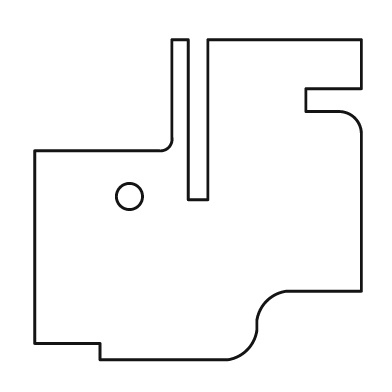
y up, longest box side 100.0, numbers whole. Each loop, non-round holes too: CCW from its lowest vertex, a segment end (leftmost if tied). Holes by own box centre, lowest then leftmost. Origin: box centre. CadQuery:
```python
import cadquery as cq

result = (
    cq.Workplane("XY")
    .moveTo(-30.0, -49.0)
    .lineTo(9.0, -49.0)
    .threePointArc((15.0, -46.0), (18.0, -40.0))
    .lineTo(18.0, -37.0)
    .threePointArc((21.0, -31.0), (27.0, -28.0))
    .lineTo(50.0, -28.0)
    .lineTo(50.0, 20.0)
    .threePointArc((48.0, 25.0), (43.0, 27.0))
    .lineTo(33.0, 27.0)
    .lineTo(33.0, 34.0)
    .lineTo(50.0, 34.0)
    .lineTo(50.0, 49.0)
    .lineTo(3.0, 49.0)
    .lineTo(3.0, 0.0)
    .lineTo(-3.0, 0.0)
    .lineTo(-3.0, 49.0)
    .lineTo(-8.0, 49.0)
    .lineTo(-8.0, 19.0)
    .threePointArc((-9.0, 16.0), (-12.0, 15.0))
    .lineTo(-50.0, 15.0)
    .lineTo(-50.0, -44.0)
    .lineTo(-30.0, -44.0)
    .close()
    .moveTo(-21.0, 1.0)
    .circle(4.0)
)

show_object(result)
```